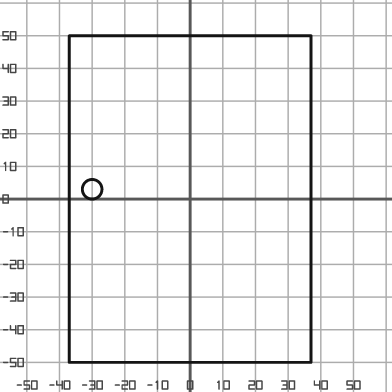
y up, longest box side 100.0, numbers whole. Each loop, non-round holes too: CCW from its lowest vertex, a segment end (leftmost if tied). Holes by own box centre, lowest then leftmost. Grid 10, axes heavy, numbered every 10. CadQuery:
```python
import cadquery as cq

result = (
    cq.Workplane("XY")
    .moveTo(-37.0, -50.0)
    .lineTo(37.0, -50.0)
    .lineTo(37.0, 50.0)
    .lineTo(-37.0, 50.0)
    .close()
    .moveTo(-30.0, 3.0)
    .circle(3.0)
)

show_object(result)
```